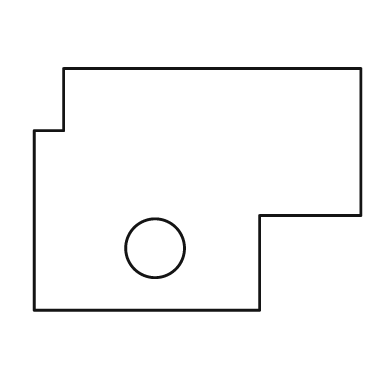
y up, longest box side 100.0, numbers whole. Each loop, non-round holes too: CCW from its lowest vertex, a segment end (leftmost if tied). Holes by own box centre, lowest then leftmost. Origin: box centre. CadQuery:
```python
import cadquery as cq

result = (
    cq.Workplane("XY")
    .moveTo(-50.0, -37.0)
    .lineTo(19.0, -37.0)
    .lineTo(19.0, -8.0)
    .lineTo(50.0, -8.0)
    .lineTo(50.0, 37.0)
    .lineTo(-41.0, 37.0)
    .lineTo(-41.0, 18.0)
    .lineTo(-50.0, 18.0)
    .close()
    .moveTo(-13.0, -18.0)
    .circle(9.0)
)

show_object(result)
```